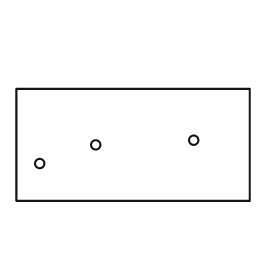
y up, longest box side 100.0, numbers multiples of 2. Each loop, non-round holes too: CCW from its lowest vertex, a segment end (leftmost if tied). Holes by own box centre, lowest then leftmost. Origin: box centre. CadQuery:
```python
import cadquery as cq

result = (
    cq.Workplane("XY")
    .moveTo(-50.0, -24.0)
    .lineTo(50.0, -24.0)
    .lineTo(50.0, 24.0)
    .lineTo(-50.0, 24.0)
    .close()
    .moveTo(-40.0, -8.0)
    .circle(2.0)
    .moveTo(-16.0, 0.0)
    .circle(2.0)
    .moveTo(26.0, 2.0)
    .circle(2.0)
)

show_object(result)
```